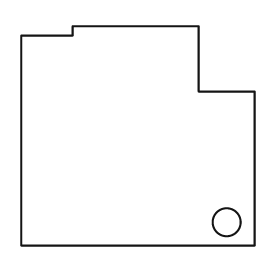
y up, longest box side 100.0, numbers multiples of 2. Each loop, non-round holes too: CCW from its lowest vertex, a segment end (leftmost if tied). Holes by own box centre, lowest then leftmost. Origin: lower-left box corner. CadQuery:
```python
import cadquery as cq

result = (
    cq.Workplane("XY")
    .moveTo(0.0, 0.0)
    .lineTo(100.0, 0.0)
    .lineTo(100.0, 66.0)
    .lineTo(76.0, 66.0)
    .lineTo(76.0, 94.0)
    .lineTo(22.0, 94.0)
    .lineTo(22.0, 90.0)
    .lineTo(0.0, 90.0)
    .close()
    .moveTo(88.0, 10.0)
    .circle(6.0)
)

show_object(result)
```